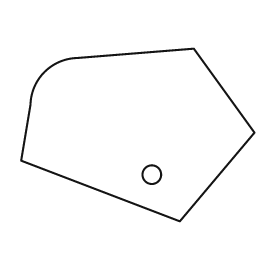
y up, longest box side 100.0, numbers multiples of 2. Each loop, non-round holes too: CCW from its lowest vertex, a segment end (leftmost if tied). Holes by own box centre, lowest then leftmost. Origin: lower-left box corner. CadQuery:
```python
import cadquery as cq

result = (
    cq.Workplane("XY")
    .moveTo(68.0, 0.0)
    .lineTo(100.0, 38.0)
    .lineTo(74.0, 74.0)
    .lineTo(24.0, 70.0)
    .threePointArc((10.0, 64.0), (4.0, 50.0))
    .lineTo(0.0, 26.0)
    .close()
    .moveTo(56.0, 20.0)
    .circle(4.0)
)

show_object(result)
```